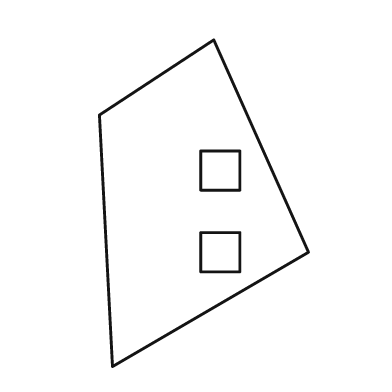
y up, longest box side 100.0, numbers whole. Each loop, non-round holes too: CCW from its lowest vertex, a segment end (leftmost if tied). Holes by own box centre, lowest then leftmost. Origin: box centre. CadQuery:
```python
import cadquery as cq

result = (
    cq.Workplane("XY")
    .moveTo(-28.0, -50.0)
    .lineTo(32.0, -15.0)
    .lineTo(3.0, 50.0)
    .lineTo(-32.0, 27.0)
    .close()
    .moveTo(-1.0, -21.0)
    .lineTo(11.0, -21.0)
    .lineTo(11.0, -9.0)
    .lineTo(-1.0, -9.0)
    .close()
    .moveTo(-1.0, 4.0)
    .lineTo(11.0, 4.0)
    .lineTo(11.0, 16.0)
    .lineTo(-1.0, 16.0)
    .close()
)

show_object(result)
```